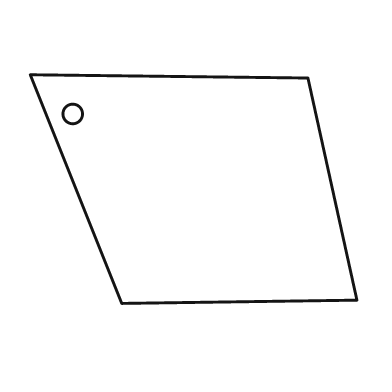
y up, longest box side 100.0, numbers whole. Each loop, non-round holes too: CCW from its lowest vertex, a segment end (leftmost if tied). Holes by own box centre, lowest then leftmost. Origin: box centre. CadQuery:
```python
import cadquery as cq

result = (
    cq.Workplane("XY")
    .moveTo(-22.0, -35.0)
    .lineTo(50.0, -34.0)
    .lineTo(35.0, 34.0)
    .lineTo(-50.0, 35.0)
    .close()
    .moveTo(-37.0, 23.0)
    .circle(3.0)
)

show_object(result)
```